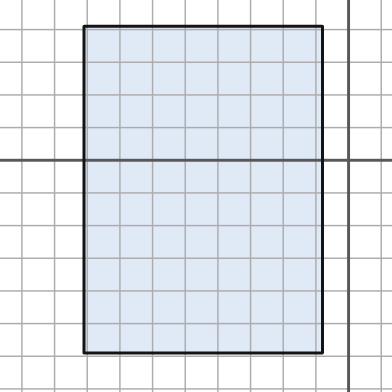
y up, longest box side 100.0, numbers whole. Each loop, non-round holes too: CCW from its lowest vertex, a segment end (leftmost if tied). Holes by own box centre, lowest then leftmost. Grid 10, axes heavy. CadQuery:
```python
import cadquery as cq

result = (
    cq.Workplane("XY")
    .moveTo(-81.0, -59.0)
    .lineTo(-8.0, -59.0)
    .lineTo(-8.0, 41.0)
    .lineTo(-81.0, 41.0)
    .close()
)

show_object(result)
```